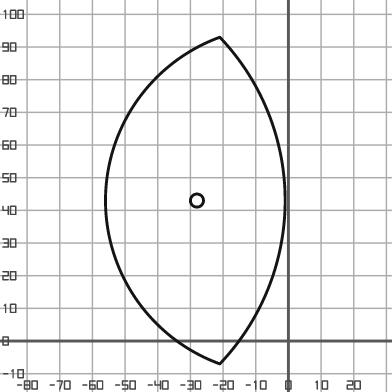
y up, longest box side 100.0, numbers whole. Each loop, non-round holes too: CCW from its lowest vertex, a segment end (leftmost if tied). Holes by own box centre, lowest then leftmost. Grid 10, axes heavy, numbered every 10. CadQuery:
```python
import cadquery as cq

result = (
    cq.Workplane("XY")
    .moveTo(-21.0, -7.0)
    .threePointArc((-1.0, 43.0), (-21.0, 93.0))
    .threePointArc((-56.0, 43.0), (-21.0, -7.0))
    .close()
    .moveTo(-28.0, 43.0)
    .circle(2.0)
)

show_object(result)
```